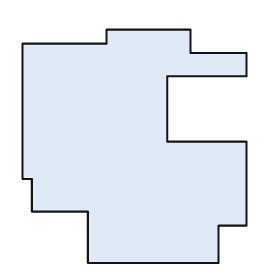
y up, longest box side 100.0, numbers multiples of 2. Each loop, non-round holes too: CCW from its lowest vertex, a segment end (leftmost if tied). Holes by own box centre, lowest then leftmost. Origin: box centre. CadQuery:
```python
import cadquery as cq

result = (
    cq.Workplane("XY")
    .moveTo(-20.0, -50.0)
    .lineTo(36.0, -50.0)
    .lineTo(36.0, -34.0)
    .lineTo(48.0, -34.0)
    .lineTo(48.0, 2.0)
    .lineTo(14.0, 2.0)
    .lineTo(14.0, 30.0)
    .lineTo(48.0, 30.0)
    .lineTo(48.0, 40.0)
    .lineTo(24.0, 40.0)
    .lineTo(24.0, 50.0)
    .lineTo(-12.0, 50.0)
    .lineTo(-12.0, 44.0)
    .lineTo(-48.0, 44.0)
    .lineTo(-48.0, -14.0)
    .lineTo(-44.0, -14.0)
    .lineTo(-44.0, -28.0)
    .lineTo(-20.0, -28.0)
    .close()
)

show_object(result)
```